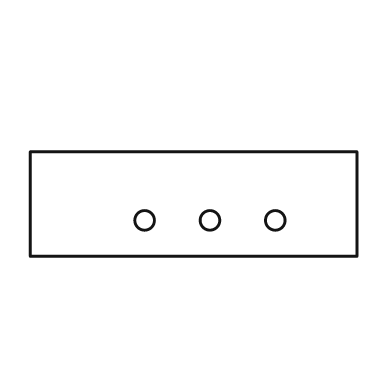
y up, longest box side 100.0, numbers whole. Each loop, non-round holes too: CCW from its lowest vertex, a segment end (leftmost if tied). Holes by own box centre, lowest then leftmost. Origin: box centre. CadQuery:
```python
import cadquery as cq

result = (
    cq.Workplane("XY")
    .moveTo(-50.0, -16.0)
    .lineTo(50.0, -16.0)
    .lineTo(50.0, 16.0)
    .lineTo(-50.0, 16.0)
    .close()
    .moveTo(-15.0, -5.0)
    .circle(3.0)
    .moveTo(5.0, -5.0)
    .circle(3.0)
    .moveTo(25.0, -5.0)
    .circle(3.0)
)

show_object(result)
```